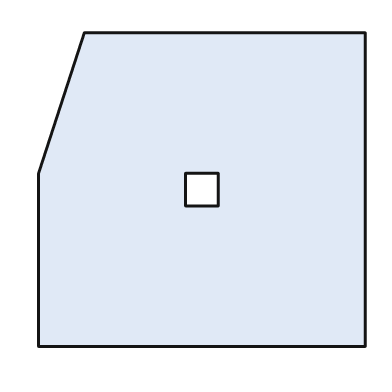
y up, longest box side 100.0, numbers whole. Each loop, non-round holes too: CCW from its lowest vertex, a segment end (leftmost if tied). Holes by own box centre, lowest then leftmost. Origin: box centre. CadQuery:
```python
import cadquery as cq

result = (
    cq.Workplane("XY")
    .moveTo(-50.0, -48.0)
    .lineTo(50.0, -48.0)
    .lineTo(50.0, 48.0)
    .lineTo(-36.0, 48.0)
    .lineTo(-50.0, 5.0)
    .close()
    .moveTo(-5.0, -5.0)
    .lineTo(5.0, -5.0)
    .lineTo(5.0, 5.0)
    .lineTo(-5.0, 5.0)
    .close()
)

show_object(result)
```